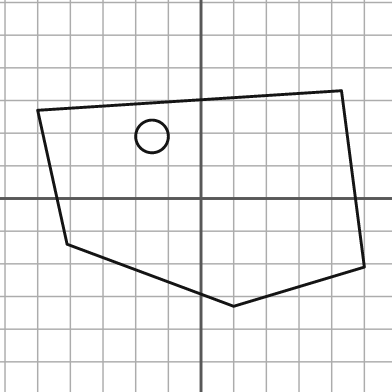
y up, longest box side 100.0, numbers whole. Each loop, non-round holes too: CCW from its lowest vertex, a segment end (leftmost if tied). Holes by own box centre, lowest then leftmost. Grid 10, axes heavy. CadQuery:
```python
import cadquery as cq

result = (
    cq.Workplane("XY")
    .moveTo(10.0, -33.0)
    .lineTo(50.0, -21.0)
    .lineTo(43.0, 33.0)
    .lineTo(-50.0, 27.0)
    .lineTo(-41.0, -14.0)
    .close()
    .moveTo(-15.0, 19.0)
    .circle(5.0)
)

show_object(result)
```